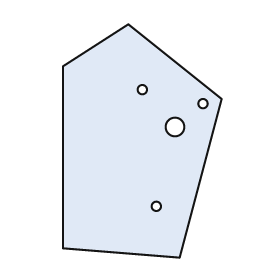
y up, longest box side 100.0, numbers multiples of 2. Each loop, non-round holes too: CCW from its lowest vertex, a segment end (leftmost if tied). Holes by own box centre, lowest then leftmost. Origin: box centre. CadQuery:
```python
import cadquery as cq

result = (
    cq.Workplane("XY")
    .moveTo(16.0, -50.0)
    .lineTo(34.0, 18.0)
    .lineTo(-6.0, 50.0)
    .lineTo(-34.0, 32.0)
    .lineTo(-34.0, -46.0)
    .close()
    .moveTo(6.0, -28.0)
    .circle(2.0)
    .moveTo(14.0, 6.0)
    .circle(4.0)
    .moveTo(26.0, 16.0)
    .circle(2.0)
    .moveTo(0.0, 22.0)
    .circle(2.0)
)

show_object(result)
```